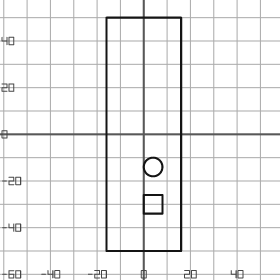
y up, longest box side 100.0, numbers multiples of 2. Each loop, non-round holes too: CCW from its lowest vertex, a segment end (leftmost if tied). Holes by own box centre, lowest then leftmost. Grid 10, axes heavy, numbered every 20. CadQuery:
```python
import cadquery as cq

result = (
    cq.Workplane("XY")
    .moveTo(-16.0, -50.0)
    .lineTo(16.0, -50.0)
    .lineTo(16.0, 50.0)
    .lineTo(-16.0, 50.0)
    .close()
    .moveTo(0.0, -34.0)
    .lineTo(8.0, -34.0)
    .lineTo(8.0, -26.0)
    .lineTo(0.0, -26.0)
    .close()
    .moveTo(4.0, -14.0)
    .circle(4.0)
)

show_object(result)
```